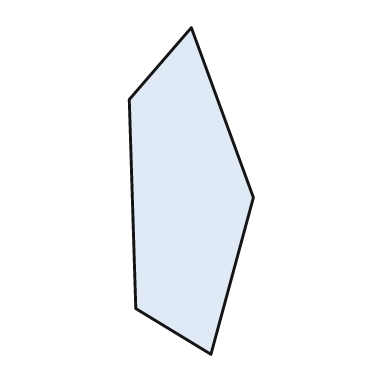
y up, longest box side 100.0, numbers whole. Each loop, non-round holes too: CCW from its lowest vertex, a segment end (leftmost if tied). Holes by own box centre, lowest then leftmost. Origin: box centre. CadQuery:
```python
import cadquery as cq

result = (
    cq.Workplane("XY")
    .moveTo(6.0, -50.0)
    .lineTo(19.0, -2.0)
    .lineTo(0.0, 50.0)
    .lineTo(-19.0, 28.0)
    .lineTo(-17.0, -36.0)
    .close()
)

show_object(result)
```